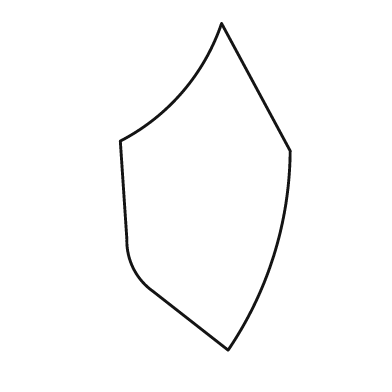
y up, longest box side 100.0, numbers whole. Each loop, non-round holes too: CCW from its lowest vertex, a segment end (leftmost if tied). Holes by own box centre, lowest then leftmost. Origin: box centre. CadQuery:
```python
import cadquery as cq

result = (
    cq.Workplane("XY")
    .moveTo(7.0, -50.0)
    .threePointArc((21.0, -21.0), (26.0, 11.0))
    .lineTo(5.0, 50.0)
    .threePointArc((-7.0, 29.0), (-26.0, 14.0))
    .lineTo(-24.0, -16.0)
    .threePointArc((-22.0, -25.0), (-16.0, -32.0))
    .close()
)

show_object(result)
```